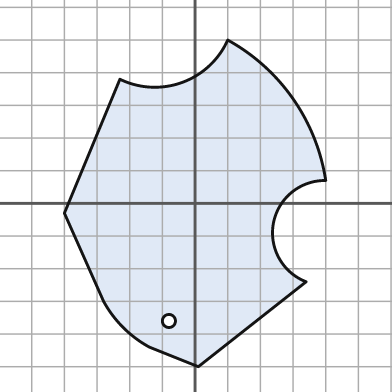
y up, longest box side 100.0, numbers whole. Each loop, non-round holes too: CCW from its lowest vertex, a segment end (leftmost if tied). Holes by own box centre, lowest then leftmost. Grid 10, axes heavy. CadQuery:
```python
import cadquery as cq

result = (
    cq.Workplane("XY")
    .moveTo(1.0, -50.0)
    .lineTo(34.0, -24.0)
    .threePointArc((24.0, -6.0), (40.0, 7.0))
    .threePointArc((30.0, 32.0), (10.0, 50.0))
    .threePointArc((-4.0, 37.0), (-23.0, 38.0))
    .lineTo(-40.0, -3.0)
    .lineTo(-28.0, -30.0)
    .threePointArc((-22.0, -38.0), (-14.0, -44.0))
    .close()
    .moveTo(-8.0, -36.0)
    .circle(2.0)
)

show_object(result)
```